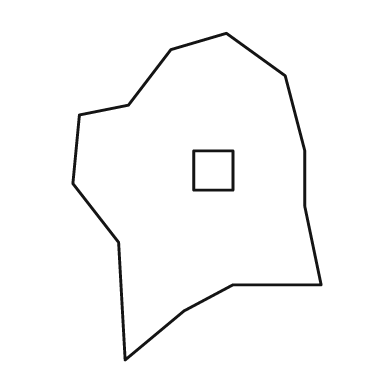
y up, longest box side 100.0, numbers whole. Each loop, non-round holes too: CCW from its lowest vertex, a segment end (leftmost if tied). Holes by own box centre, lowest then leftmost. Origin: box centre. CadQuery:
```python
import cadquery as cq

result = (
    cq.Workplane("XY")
    .moveTo(-22.0, -50.0)
    .lineTo(-4.0, -35.0)
    .lineTo(11.0, -27.0)
    .lineTo(38.0, -27.0)
    .lineTo(33.0, -3.0)
    .lineTo(33.0, 14.0)
    .lineTo(27.0, 37.0)
    .lineTo(9.0, 50.0)
    .lineTo(-8.0, 45.0)
    .lineTo(-21.0, 28.0)
    .lineTo(-36.0, 25.0)
    .lineTo(-38.0, 4.0)
    .lineTo(-24.0, -14.0)
    .close()
    .moveTo(-1.0, 2.0)
    .lineTo(11.0, 2.0)
    .lineTo(11.0, 14.0)
    .lineTo(-1.0, 14.0)
    .close()
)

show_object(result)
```